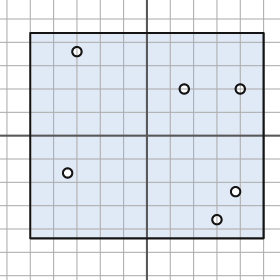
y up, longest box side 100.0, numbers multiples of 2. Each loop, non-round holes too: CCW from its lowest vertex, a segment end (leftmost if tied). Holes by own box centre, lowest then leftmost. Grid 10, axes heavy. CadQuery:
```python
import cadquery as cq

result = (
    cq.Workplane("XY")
    .moveTo(-50.0, -44.0)
    .lineTo(50.0, -44.0)
    .lineTo(50.0, 44.0)
    .lineTo(-50.0, 44.0)
    .close()
    .moveTo(30.0, -36.0)
    .circle(2.0)
    .moveTo(38.0, -24.0)
    .circle(2.0)
    .moveTo(-34.0, -16.0)
    .circle(2.0)
    .moveTo(16.0, 20.0)
    .circle(2.0)
    .moveTo(40.0, 20.0)
    .circle(2.0)
    .moveTo(-30.0, 36.0)
    .circle(2.0)
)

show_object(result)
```